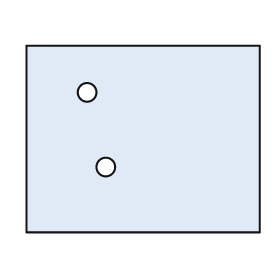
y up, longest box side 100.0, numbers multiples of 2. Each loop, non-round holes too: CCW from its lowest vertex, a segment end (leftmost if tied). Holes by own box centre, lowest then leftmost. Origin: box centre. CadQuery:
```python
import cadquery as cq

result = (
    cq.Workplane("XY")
    .moveTo(-50.0, -40.0)
    .lineTo(50.0, -40.0)
    .lineTo(50.0, 40.0)
    .lineTo(-50.0, 40.0)
    .close()
    .moveTo(-16.0, -12.0)
    .circle(4.0)
    .moveTo(-24.0, 20.0)
    .circle(4.0)
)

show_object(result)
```